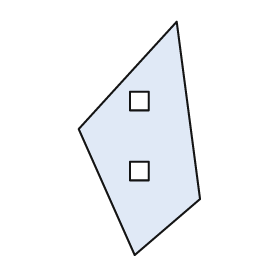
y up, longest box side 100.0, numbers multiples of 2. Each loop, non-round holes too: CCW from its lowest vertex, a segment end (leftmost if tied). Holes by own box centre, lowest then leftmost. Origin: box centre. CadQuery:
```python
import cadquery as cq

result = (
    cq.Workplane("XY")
    .moveTo(-2.0, -50.0)
    .lineTo(26.0, -26.0)
    .lineTo(16.0, 50.0)
    .lineTo(-26.0, 4.0)
    .close()
    .moveTo(-4.0, -18.0)
    .lineTo(4.0, -18.0)
    .lineTo(4.0, -10.0)
    .lineTo(-4.0, -10.0)
    .close()
    .moveTo(-4.0, 12.0)
    .lineTo(4.0, 12.0)
    .lineTo(4.0, 20.0)
    .lineTo(-4.0, 20.0)
    .close()
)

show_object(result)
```